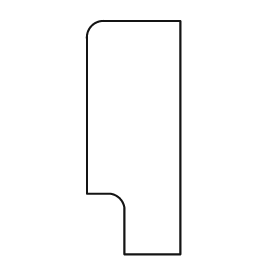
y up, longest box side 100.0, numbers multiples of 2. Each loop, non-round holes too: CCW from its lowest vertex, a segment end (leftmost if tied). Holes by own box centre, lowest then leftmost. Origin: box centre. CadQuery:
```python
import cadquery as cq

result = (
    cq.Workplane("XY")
    .moveTo(-4.0, -50.0)
    .lineTo(20.0, -50.0)
    .lineTo(20.0, 50.0)
    .lineTo(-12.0, 50.0)
    .threePointArc((-18.0, 48.0), (-20.0, 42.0))
    .lineTo(-20.0, -24.0)
    .lineTo(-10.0, -24.0)
    .threePointArc((-6.0, -26.0), (-4.0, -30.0))
    .close()
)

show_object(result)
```